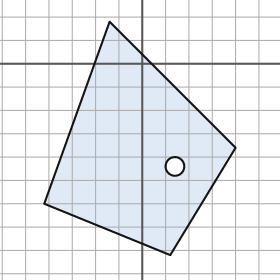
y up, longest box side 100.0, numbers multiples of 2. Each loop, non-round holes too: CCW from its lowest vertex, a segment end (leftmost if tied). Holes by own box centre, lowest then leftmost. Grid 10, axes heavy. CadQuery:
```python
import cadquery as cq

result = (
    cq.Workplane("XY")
    .moveTo(12.0, -82.0)
    .lineTo(40.0, -36.0)
    .lineTo(-14.0, 18.0)
    .lineTo(-42.0, -60.0)
    .close()
    .moveTo(14.0, -44.0)
    .circle(4.0)
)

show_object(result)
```